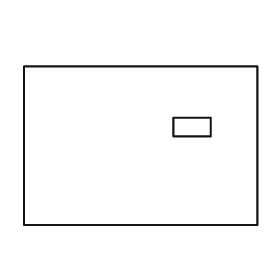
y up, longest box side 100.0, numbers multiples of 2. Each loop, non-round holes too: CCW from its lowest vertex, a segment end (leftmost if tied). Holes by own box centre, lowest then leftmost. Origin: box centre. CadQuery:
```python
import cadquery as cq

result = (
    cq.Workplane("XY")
    .moveTo(-50.0, -34.0)
    .lineTo(50.0, -34.0)
    .lineTo(50.0, 34.0)
    .lineTo(-50.0, 34.0)
    .close()
    .moveTo(14.0, 4.0)
    .lineTo(30.0, 4.0)
    .lineTo(30.0, 12.0)
    .lineTo(14.0, 12.0)
    .close()
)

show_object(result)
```